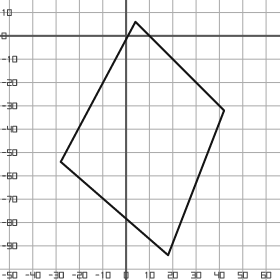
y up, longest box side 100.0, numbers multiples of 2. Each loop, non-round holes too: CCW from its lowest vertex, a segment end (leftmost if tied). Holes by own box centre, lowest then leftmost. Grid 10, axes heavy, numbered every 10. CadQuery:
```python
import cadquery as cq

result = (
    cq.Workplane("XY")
    .moveTo(18.0, -94.0)
    .lineTo(42.0, -32.0)
    .lineTo(4.0, 6.0)
    .lineTo(-28.0, -54.0)
    .close()
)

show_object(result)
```